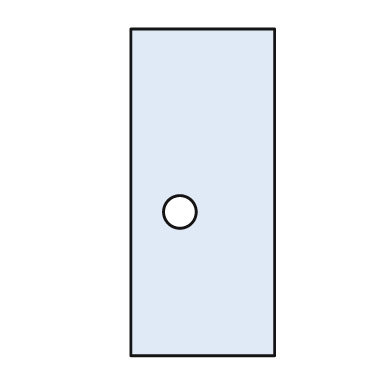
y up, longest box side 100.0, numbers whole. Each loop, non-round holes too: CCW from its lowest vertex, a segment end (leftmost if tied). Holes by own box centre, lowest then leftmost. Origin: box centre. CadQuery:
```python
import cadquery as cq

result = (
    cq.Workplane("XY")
    .moveTo(-22.0, -50.0)
    .lineTo(22.0, -50.0)
    .lineTo(22.0, 50.0)
    .lineTo(-22.0, 50.0)
    .close()
    .moveTo(-7.0, -6.0)
    .circle(5.0)
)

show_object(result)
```